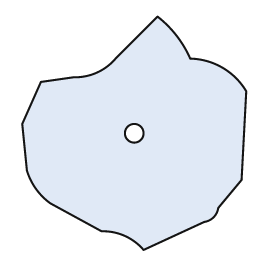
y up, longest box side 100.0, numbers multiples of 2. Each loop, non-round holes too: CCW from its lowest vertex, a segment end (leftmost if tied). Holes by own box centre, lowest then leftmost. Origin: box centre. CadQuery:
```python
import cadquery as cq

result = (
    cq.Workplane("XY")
    .moveTo(4.0, -50.0)
    .lineTo(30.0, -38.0)
    .threePointArc((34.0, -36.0), (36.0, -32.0))
    .lineTo(46.0, -20.0)
    .lineTo(48.0, 18.0)
    .threePointArc((38.0, 28.0), (24.0, 32.0))
    .threePointArc((18.0, 42.0), (10.0, 50.0))
    .lineTo(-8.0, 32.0)
    .threePointArc((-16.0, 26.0), (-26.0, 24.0))
    .lineTo(-40.0, 22.0)
    .lineTo(-48.0, 4.0)
    .lineTo(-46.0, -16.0)
    .threePointArc((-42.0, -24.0), (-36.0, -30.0))
    .lineTo(-14.0, -42.0)
    .threePointArc((-4.0, -44.0), (4.0, -50.0))
    .close()
    .moveTo(0.0, 0.0)
    .circle(4.0)
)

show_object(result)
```